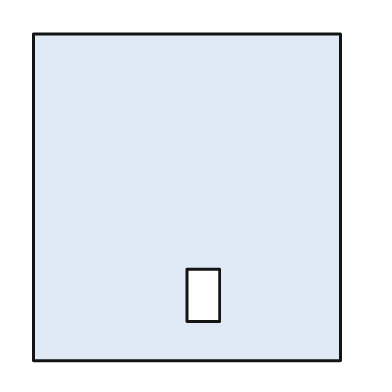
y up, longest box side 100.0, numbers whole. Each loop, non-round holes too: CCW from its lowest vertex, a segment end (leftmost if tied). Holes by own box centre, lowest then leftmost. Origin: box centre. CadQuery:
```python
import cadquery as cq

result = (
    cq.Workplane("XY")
    .moveTo(-47.0, -50.0)
    .lineTo(47.0, -50.0)
    .lineTo(47.0, 50.0)
    .lineTo(-47.0, 50.0)
    .close()
    .moveTo(0.0, -38.0)
    .lineTo(10.0, -38.0)
    .lineTo(10.0, -22.0)
    .lineTo(0.0, -22.0)
    .close()
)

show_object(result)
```